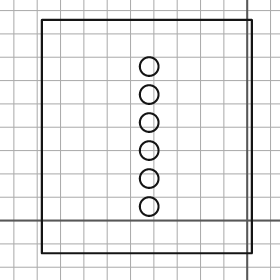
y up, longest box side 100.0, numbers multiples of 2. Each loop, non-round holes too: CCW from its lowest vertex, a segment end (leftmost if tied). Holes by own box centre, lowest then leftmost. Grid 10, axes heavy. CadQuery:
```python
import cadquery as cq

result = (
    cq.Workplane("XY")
    .moveTo(-88.0, -14.0)
    .lineTo(2.0, -14.0)
    .lineTo(2.0, 86.0)
    .lineTo(-88.0, 86.0)
    .close()
    .moveTo(-42.0, 6.0)
    .circle(4.0)
    .moveTo(-42.0, 18.0)
    .circle(4.0)
    .moveTo(-42.0, 30.0)
    .circle(4.0)
    .moveTo(-42.0, 42.0)
    .circle(4.0)
    .moveTo(-42.0, 54.0)
    .circle(4.0)
    .moveTo(-42.0, 66.0)
    .circle(4.0)
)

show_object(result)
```